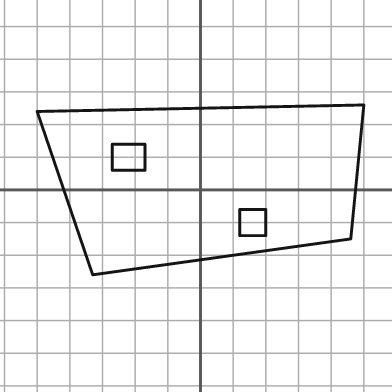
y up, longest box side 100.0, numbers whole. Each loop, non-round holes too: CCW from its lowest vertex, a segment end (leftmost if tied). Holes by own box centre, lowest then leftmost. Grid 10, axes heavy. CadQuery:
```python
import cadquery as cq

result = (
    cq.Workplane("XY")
    .moveTo(-33.0, -26.0)
    .lineTo(46.0, -15.0)
    .lineTo(50.0, 26.0)
    .lineTo(-50.0, 24.0)
    .close()
    .moveTo(12.0, -14.0)
    .lineTo(20.0, -14.0)
    .lineTo(20.0, -6.0)
    .lineTo(12.0, -6.0)
    .close()
    .moveTo(-27.0, 6.0)
    .lineTo(-17.0, 6.0)
    .lineTo(-17.0, 14.0)
    .lineTo(-27.0, 14.0)
    .close()
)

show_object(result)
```